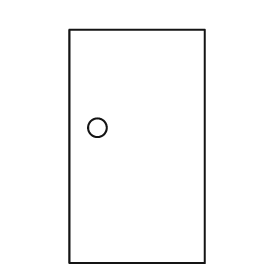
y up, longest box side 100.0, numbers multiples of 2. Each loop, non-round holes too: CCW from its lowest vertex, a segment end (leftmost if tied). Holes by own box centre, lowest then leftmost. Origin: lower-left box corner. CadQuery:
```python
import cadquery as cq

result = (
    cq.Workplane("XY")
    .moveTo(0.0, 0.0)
    .lineTo(58.0, 0.0)
    .lineTo(58.0, 100.0)
    .lineTo(0.0, 100.0)
    .close()
    .moveTo(12.0, 58.0)
    .circle(4.0)
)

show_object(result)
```